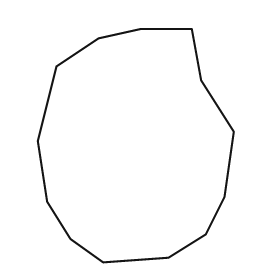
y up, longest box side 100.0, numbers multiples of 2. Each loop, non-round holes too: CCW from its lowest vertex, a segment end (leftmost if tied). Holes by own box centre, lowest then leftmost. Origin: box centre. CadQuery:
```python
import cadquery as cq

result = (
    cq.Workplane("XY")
    .moveTo(-14.0, -50.0)
    .lineTo(14.0, -48.0)
    .lineTo(30.0, -38.0)
    .lineTo(38.0, -22.0)
    .lineTo(42.0, 6.0)
    .lineTo(28.0, 28.0)
    .lineTo(24.0, 50.0)
    .lineTo(2.0, 50.0)
    .lineTo(-16.0, 46.0)
    .lineTo(-34.0, 34.0)
    .lineTo(-42.0, 2.0)
    .lineTo(-38.0, -24.0)
    .lineTo(-28.0, -40.0)
    .close()
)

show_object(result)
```